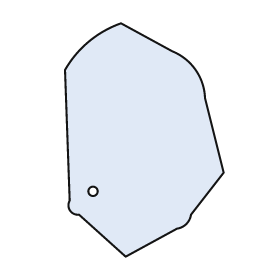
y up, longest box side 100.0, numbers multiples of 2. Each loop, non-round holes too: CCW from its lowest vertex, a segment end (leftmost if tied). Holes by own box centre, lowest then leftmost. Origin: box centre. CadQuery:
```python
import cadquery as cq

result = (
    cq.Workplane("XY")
    .moveTo(-8.0, -50.0)
    .lineTo(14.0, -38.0)
    .threePointArc((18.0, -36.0), (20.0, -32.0))
    .lineTo(34.0, -14.0)
    .lineTo(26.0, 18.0)
    .threePointArc((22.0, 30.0), (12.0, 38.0))
    .lineTo(-10.0, 50.0)
    .threePointArc((-24.0, 42.0), (-34.0, 30.0))
    .lineTo(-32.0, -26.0)
    .threePointArc((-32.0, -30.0), (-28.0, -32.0))
    .close()
    .moveTo(-22.0, -22.0)
    .circle(2.0)
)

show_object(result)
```